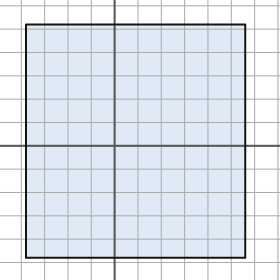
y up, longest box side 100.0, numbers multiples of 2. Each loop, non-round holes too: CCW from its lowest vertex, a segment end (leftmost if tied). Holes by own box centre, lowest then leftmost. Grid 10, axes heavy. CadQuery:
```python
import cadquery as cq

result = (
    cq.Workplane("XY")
    .moveTo(-38.0, -48.0)
    .lineTo(56.0, -48.0)
    .lineTo(56.0, 52.0)
    .lineTo(-38.0, 52.0)
    .close()
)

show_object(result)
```